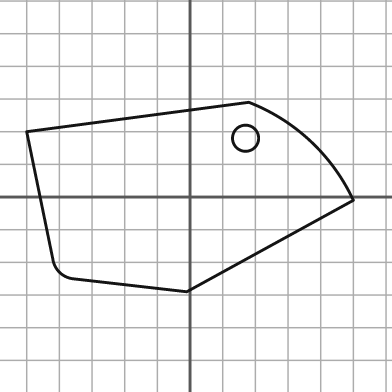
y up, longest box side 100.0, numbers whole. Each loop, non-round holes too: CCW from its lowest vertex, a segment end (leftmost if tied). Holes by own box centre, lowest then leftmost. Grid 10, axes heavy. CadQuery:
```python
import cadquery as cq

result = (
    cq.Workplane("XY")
    .moveTo(-1.0, -29.0)
    .lineTo(50.0, -1.0)
    .threePointArc((37.0, 17.0), (18.0, 29.0))
    .lineTo(-50.0, 20.0)
    .lineTo(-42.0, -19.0)
    .threePointArc((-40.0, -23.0), (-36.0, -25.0))
    .close()
    .moveTo(17.0, 18.0)
    .circle(4.0)
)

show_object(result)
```